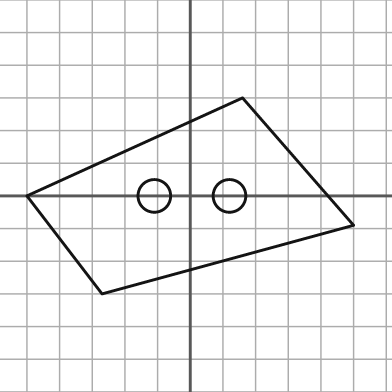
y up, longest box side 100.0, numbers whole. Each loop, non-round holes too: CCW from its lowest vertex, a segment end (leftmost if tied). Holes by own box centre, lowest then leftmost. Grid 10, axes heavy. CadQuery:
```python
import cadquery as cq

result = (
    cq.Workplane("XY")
    .moveTo(-27.0, -30.0)
    .lineTo(50.0, -9.0)
    .lineTo(16.0, 30.0)
    .lineTo(-50.0, 0.0)
    .close()
    .moveTo(-11.0, 0.0)
    .circle(5.0)
    .moveTo(12.0, 0.0)
    .circle(5.0)
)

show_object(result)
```